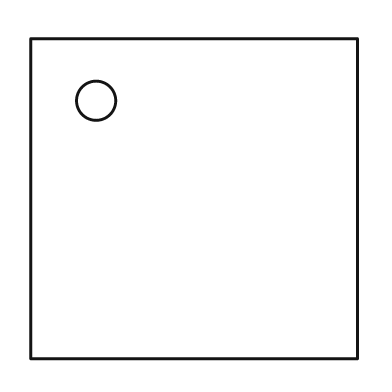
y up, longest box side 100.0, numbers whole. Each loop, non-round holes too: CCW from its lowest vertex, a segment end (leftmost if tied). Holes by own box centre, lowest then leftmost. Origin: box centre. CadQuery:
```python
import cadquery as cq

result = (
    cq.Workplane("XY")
    .moveTo(-50.0, -49.0)
    .lineTo(50.0, -49.0)
    .lineTo(50.0, 49.0)
    .lineTo(-50.0, 49.0)
    .close()
    .moveTo(-30.0, 30.0)
    .circle(6.0)
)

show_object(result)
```